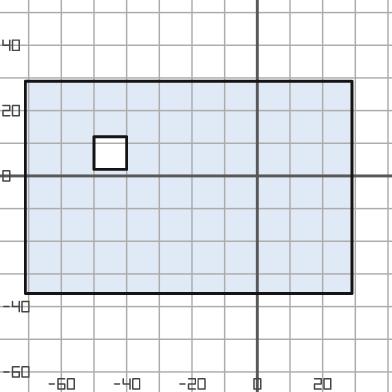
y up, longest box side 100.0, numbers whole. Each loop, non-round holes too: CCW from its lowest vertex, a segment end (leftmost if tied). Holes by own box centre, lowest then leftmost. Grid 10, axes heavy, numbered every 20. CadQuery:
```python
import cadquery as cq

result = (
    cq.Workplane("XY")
    .moveTo(-71.0, -36.0)
    .lineTo(29.0, -36.0)
    .lineTo(29.0, 29.0)
    .lineTo(-71.0, 29.0)
    .close()
    .moveTo(-50.0, 2.0)
    .lineTo(-40.0, 2.0)
    .lineTo(-40.0, 12.0)
    .lineTo(-50.0, 12.0)
    .close()
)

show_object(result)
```